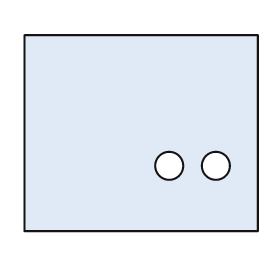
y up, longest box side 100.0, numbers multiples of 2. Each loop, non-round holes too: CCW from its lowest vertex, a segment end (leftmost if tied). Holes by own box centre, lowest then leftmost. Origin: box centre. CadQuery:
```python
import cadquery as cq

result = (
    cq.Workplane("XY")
    .moveTo(-50.0, -42.0)
    .lineTo(50.0, -42.0)
    .lineTo(50.0, 42.0)
    .lineTo(-50.0, 42.0)
    .close()
    .moveTo(12.0, -14.0)
    .circle(6.0)
    .moveTo(32.0, -14.0)
    .circle(6.0)
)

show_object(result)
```